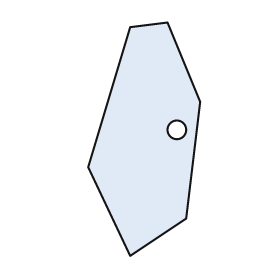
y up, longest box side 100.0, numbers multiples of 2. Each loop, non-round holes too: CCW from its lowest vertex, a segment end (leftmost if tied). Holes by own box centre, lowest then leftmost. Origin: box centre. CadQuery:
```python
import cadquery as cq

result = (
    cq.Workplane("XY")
    .moveTo(-6.0, -50.0)
    .lineTo(18.0, -34.0)
    .lineTo(24.0, 16.0)
    .lineTo(10.0, 50.0)
    .lineTo(-6.0, 48.0)
    .lineTo(-24.0, -12.0)
    .close()
    .moveTo(14.0, 4.0)
    .circle(4.0)
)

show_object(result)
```